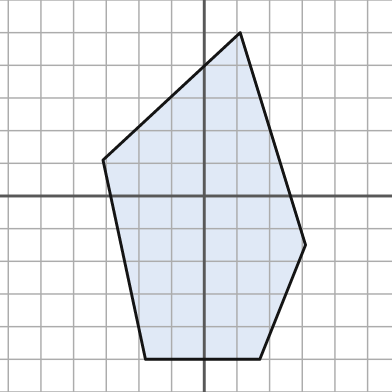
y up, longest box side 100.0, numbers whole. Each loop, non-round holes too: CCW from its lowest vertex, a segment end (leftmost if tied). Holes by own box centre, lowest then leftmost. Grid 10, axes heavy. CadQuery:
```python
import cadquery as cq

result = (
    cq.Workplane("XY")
    .moveTo(-18.0, -50.0)
    .lineTo(17.0, -50.0)
    .lineTo(31.0, -15.0)
    .lineTo(11.0, 50.0)
    .lineTo(-31.0, 11.0)
    .close()
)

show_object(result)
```